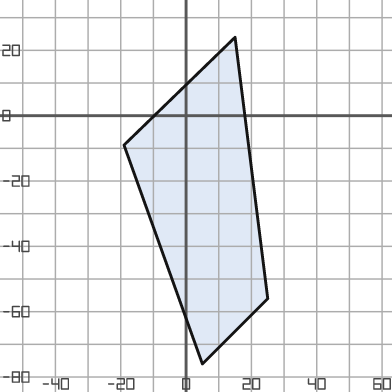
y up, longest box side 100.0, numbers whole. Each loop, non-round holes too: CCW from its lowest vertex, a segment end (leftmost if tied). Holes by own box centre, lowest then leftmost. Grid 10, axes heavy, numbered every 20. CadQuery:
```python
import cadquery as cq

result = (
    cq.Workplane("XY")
    .moveTo(5.0, -76.0)
    .lineTo(25.0, -56.0)
    .lineTo(15.0, 24.0)
    .lineTo(-19.0, -9.0)
    .close()
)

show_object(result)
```